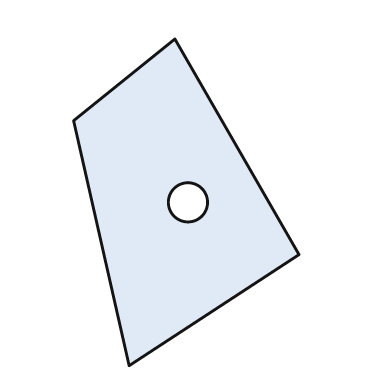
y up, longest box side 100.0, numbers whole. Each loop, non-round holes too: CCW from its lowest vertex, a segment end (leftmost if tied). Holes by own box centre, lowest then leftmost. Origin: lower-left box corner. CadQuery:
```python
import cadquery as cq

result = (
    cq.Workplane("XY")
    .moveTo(17.0, 0.0)
    .lineTo(69.0, 34.0)
    .lineTo(31.0, 100.0)
    .lineTo(0.0, 75.0)
    .close()
    .moveTo(35.0, 50.0)
    .circle(6.0)
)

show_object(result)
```